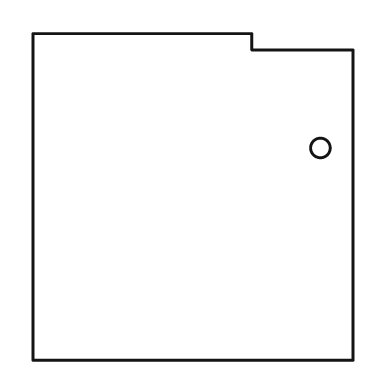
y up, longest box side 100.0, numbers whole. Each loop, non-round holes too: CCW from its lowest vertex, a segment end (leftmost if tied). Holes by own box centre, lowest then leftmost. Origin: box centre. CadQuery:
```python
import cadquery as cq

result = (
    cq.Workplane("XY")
    .moveTo(-49.0, -50.0)
    .lineTo(49.0, -50.0)
    .lineTo(49.0, 45.0)
    .lineTo(18.0, 45.0)
    .lineTo(18.0, 50.0)
    .lineTo(-49.0, 50.0)
    .close()
    .moveTo(39.0, 15.0)
    .circle(3.0)
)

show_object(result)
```